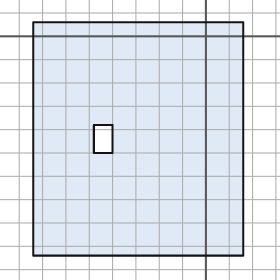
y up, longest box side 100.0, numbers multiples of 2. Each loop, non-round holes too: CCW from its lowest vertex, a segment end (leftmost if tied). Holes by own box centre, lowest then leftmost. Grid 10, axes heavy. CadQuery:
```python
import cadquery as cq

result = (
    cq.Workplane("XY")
    .moveTo(-74.0, -94.0)
    .lineTo(16.0, -94.0)
    .lineTo(16.0, 6.0)
    .lineTo(-74.0, 6.0)
    .close()
    .moveTo(-48.0, -50.0)
    .lineTo(-40.0, -50.0)
    .lineTo(-40.0, -38.0)
    .lineTo(-48.0, -38.0)
    .close()
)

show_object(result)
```